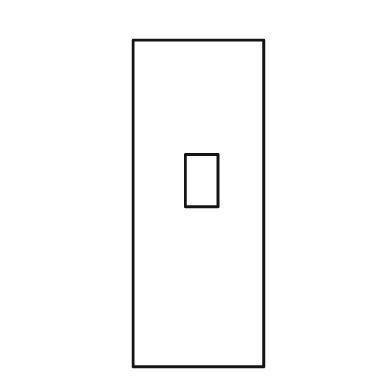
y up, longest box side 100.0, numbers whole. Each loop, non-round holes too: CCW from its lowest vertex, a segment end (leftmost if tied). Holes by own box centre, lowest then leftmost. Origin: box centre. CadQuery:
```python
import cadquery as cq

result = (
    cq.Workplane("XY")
    .moveTo(-20.0, -50.0)
    .lineTo(20.0, -50.0)
    .lineTo(20.0, 50.0)
    .lineTo(-20.0, 50.0)
    .close()
    .moveTo(-4.0, -1.0)
    .lineTo(6.0, -1.0)
    .lineTo(6.0, 15.0)
    .lineTo(-4.0, 15.0)
    .close()
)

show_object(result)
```